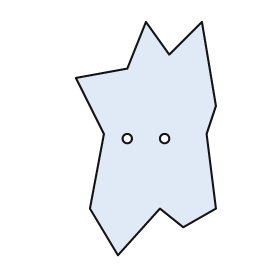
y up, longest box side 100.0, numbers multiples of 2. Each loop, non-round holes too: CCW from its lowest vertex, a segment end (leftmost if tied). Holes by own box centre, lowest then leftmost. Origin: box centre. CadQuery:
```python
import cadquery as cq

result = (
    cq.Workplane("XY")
    .moveTo(-12.0, -50.0)
    .lineTo(6.0, -30.0)
    .lineTo(16.0, -38.0)
    .lineTo(30.0, -30.0)
    .lineTo(26.0, 2.0)
    .lineTo(30.0, 14.0)
    .lineTo(24.0, 50.0)
    .lineTo(10.0, 36.0)
    .lineTo(0.0, 50.0)
    .lineTo(-8.0, 30.0)
    .lineTo(-30.0, 26.0)
    .lineTo(-18.0, 2.0)
    .lineTo(-24.0, -30.0)
    .close()
    .moveTo(-8.0, 0.0)
    .circle(2.0)
    .moveTo(8.0, 0.0)
    .circle(2.0)
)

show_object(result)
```